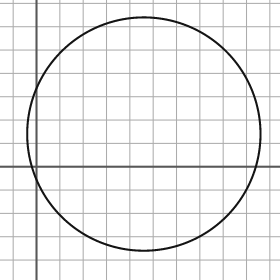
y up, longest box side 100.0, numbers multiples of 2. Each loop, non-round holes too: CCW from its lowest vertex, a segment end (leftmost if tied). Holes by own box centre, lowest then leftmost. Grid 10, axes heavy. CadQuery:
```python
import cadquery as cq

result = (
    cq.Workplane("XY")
    .moveTo(46.0, 14.0)
    .circle(50.0)
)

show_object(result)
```